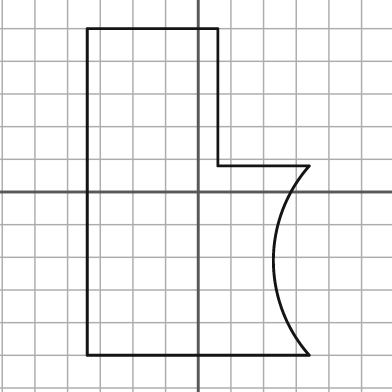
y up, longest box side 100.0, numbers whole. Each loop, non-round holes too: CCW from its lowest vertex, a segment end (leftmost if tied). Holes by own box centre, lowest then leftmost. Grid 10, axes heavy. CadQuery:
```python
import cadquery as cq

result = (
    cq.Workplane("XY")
    .moveTo(-34.0, -50.0)
    .lineTo(34.0, -50.0)
    .threePointArc((23.0, -21.0), (34.0, 8.0))
    .lineTo(6.0, 8.0)
    .lineTo(6.0, 50.0)
    .lineTo(-34.0, 50.0)
    .close()
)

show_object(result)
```